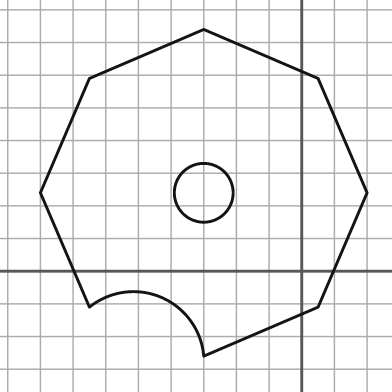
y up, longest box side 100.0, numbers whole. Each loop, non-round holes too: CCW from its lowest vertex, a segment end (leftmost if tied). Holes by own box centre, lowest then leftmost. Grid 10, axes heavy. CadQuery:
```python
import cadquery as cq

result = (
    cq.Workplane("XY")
    .moveTo(-30.0, -26.0)
    .lineTo(5.0, -11.0)
    .lineTo(20.0, 24.0)
    .lineTo(5.0, 59.0)
    .lineTo(-30.0, 74.0)
    .lineTo(-65.0, 59.0)
    .lineTo(-80.0, 24.0)
    .lineTo(-65.0, -11.0)
    .threePointArc((-43.0, -8.0), (-30.0, -26.0))
    .close()
    .moveTo(-30.0, 24.0)
    .circle(9.0)
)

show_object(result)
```